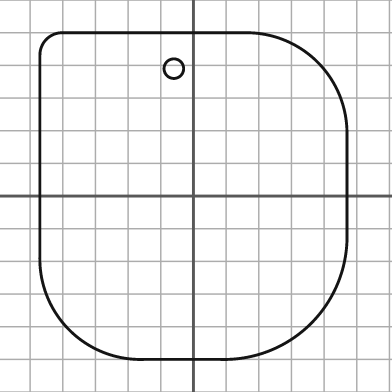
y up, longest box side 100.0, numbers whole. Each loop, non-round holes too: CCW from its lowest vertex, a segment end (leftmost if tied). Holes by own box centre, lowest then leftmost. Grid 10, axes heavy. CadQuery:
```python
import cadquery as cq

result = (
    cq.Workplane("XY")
    .moveTo(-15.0, -50.0)
    .lineTo(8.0, -50.0)
    .threePointArc((36.0, -39.0), (47.0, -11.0))
    .lineTo(47.0, 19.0)
    .threePointArc((38.0, 41.0), (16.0, 50.0))
    .lineTo(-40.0, 50.0)
    .threePointArc((-45.0, 48.0), (-47.0, 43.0))
    .lineTo(-47.0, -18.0)
    .threePointArc((-38.0, -41.0), (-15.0, -50.0))
    .close()
    .moveTo(-6.0, 39.0)
    .circle(3.0)
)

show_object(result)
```